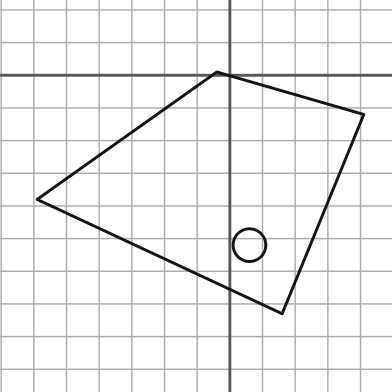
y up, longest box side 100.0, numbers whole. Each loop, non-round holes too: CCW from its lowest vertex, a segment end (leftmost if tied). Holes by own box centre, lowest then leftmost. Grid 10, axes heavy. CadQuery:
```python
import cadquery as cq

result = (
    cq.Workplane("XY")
    .moveTo(16.0, -73.0)
    .lineTo(41.0, -12.0)
    .lineTo(-4.0, 1.0)
    .lineTo(-59.0, -38.0)
    .close()
    .moveTo(6.0, -52.0)
    .circle(5.0)
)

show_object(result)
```